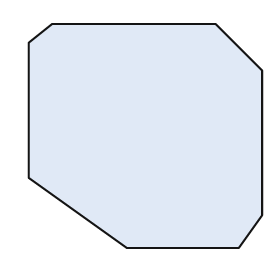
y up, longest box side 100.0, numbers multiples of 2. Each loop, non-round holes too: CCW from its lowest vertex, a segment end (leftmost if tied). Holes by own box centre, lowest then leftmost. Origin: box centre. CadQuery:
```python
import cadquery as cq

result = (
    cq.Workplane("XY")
    .moveTo(-8.0, -48.0)
    .lineTo(40.0, -48.0)
    .lineTo(50.0, -34.0)
    .lineTo(50.0, 28.0)
    .lineTo(30.0, 48.0)
    .lineTo(-40.0, 48.0)
    .lineTo(-50.0, 40.0)
    .lineTo(-50.0, -18.0)
    .close()
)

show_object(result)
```